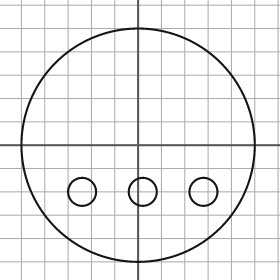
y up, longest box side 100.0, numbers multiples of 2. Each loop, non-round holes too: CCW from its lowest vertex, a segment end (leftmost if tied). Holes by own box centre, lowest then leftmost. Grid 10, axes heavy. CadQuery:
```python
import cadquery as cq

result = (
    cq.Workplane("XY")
    .moveTo(0.0, 0.0)
    .circle(50.0)
    .moveTo(-24.0, -20.0)
    .circle(6.0)
    .moveTo(2.0, -20.0)
    .circle(6.0)
    .moveTo(28.0, -20.0)
    .circle(6.0)
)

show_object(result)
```